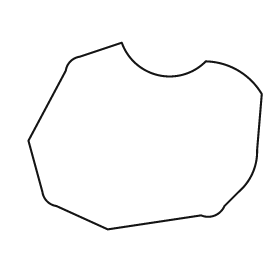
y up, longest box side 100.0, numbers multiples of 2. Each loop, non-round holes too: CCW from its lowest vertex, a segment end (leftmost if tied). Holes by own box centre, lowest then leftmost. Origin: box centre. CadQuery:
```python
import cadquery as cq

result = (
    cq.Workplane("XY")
    .moveTo(-16.0, -40.0)
    .lineTo(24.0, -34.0)
    .threePointArc((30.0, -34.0), (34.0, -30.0))
    .lineTo(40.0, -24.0)
    .threePointArc((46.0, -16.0), (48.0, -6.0))
    .lineTo(50.0, 18.0)
    .threePointArc((40.0, 28.0), (26.0, 32.0))
    .threePointArc((6.0, 26.0), (-10.0, 40.0))
    .lineTo(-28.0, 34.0)
    .threePointArc((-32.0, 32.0), (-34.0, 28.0))
    .lineTo(-50.0, -2.0)
    .lineTo(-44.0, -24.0)
    .threePointArc((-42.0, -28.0), (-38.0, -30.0))
    .close()
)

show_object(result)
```